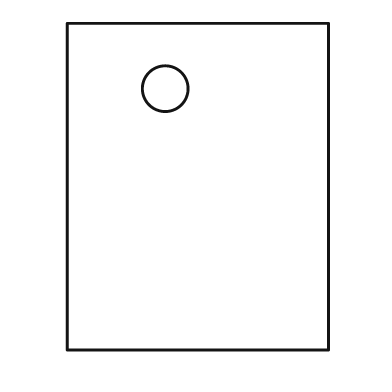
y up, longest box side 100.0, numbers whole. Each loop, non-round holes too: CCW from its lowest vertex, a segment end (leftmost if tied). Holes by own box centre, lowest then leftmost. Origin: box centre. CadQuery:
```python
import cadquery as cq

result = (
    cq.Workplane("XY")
    .moveTo(-40.0, -50.0)
    .lineTo(40.0, -50.0)
    .lineTo(40.0, 50.0)
    .lineTo(-40.0, 50.0)
    .close()
    .moveTo(-10.0, 30.0)
    .circle(7.0)
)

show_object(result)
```